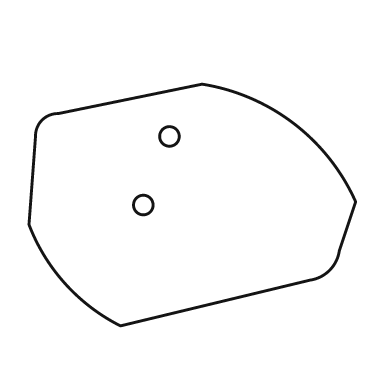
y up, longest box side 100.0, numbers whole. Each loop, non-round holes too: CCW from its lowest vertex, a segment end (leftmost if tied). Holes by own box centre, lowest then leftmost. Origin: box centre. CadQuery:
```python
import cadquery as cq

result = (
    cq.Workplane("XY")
    .moveTo(-22.0, -37.0)
    .lineTo(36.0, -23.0)
    .threePointArc((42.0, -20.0), (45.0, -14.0))
    .lineTo(50.0, 1.0)
    .threePointArc((31.0, 25.0), (3.0, 37.0))
    .lineTo(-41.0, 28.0)
    .threePointArc((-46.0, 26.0), (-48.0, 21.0))
    .lineTo(-50.0, -6.0)
    .threePointArc((-39.0, -24.0), (-22.0, -37.0))
    .close()
    .moveTo(-15.0, 0.0)
    .circle(3.0)
    .moveTo(-7.0, 21.0)
    .circle(3.0)
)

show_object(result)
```